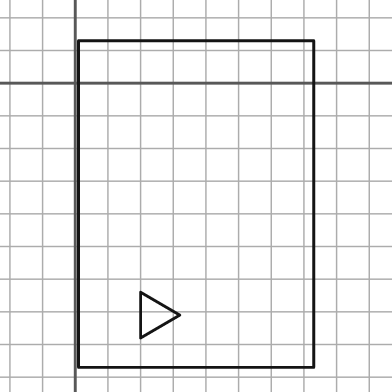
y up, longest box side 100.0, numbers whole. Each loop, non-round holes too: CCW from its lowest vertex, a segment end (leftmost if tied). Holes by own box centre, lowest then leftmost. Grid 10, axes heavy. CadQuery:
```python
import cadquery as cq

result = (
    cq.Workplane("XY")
    .moveTo(1.0, -87.0)
    .lineTo(73.0, -87.0)
    .lineTo(73.0, 13.0)
    .lineTo(1.0, 13.0)
    .close()
    .moveTo(20.0, -78.0)
    .lineTo(32.0, -71.0)
    .lineTo(20.0, -64.0)
    .close()
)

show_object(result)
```